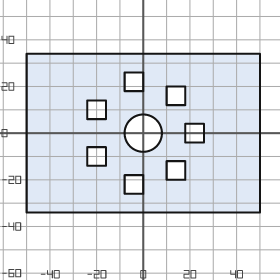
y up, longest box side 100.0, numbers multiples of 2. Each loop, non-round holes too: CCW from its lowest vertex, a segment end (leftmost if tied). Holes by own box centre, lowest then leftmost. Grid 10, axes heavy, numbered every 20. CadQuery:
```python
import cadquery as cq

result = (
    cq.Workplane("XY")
    .moveTo(-50.0, -34.0)
    .lineTo(50.0, -34.0)
    .lineTo(50.0, 34.0)
    .lineTo(-50.0, 34.0)
    .close()
    .moveTo(-8.0, -26.0)
    .lineTo(0.0, -26.0)
    .lineTo(0.0, -18.0)
    .lineTo(-8.0, -18.0)
    .close()
    .moveTo(10.0, -20.0)
    .lineTo(18.0, -20.0)
    .lineTo(18.0, -12.0)
    .lineTo(10.0, -12.0)
    .close()
    .moveTo(-24.0, -14.0)
    .lineTo(-16.0, -14.0)
    .lineTo(-16.0, -6.0)
    .lineTo(-24.0, -6.0)
    .close()
    .moveTo(0.0, 0.0)
    .circle(8.0)
    .moveTo(18.0, -4.0)
    .lineTo(26.0, -4.0)
    .lineTo(26.0, 4.0)
    .lineTo(18.0, 4.0)
    .close()
    .moveTo(-24.0, 6.0)
    .lineTo(-16.0, 6.0)
    .lineTo(-16.0, 14.0)
    .lineTo(-24.0, 14.0)
    .close()
    .moveTo(10.0, 12.0)
    .lineTo(18.0, 12.0)
    .lineTo(18.0, 20.0)
    .lineTo(10.0, 20.0)
    .close()
    .moveTo(-8.0, 18.0)
    .lineTo(0.0, 18.0)
    .lineTo(0.0, 26.0)
    .lineTo(-8.0, 26.0)
    .close()
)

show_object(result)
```